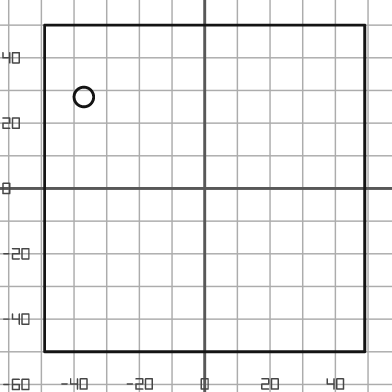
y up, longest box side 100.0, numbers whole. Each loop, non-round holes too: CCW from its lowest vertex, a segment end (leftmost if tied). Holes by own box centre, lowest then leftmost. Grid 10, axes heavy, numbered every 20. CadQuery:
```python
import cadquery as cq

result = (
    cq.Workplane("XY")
    .moveTo(-49.0, -50.0)
    .lineTo(49.0, -50.0)
    .lineTo(49.0, 50.0)
    .lineTo(-49.0, 50.0)
    .close()
    .moveTo(-37.0, 28.0)
    .circle(3.0)
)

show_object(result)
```